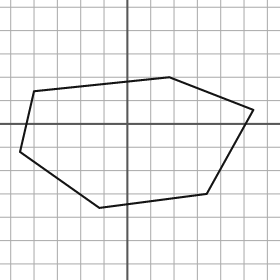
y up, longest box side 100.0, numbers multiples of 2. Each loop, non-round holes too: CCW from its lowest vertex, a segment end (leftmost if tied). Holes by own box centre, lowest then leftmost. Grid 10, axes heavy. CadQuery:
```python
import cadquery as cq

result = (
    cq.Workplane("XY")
    .moveTo(-12.0, -36.0)
    .lineTo(34.0, -30.0)
    .lineTo(54.0, 6.0)
    .lineTo(18.0, 20.0)
    .lineTo(-40.0, 14.0)
    .lineTo(-46.0, -12.0)
    .close()
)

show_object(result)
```